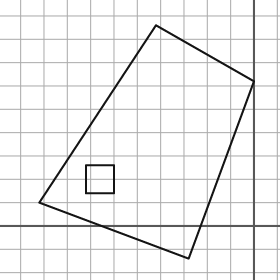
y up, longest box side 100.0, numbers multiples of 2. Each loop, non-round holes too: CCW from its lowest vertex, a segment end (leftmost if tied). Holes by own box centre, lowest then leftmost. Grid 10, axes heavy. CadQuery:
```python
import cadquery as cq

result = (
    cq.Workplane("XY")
    .moveTo(-28.0, -14.0)
    .lineTo(0.0, 62.0)
    .lineTo(-42.0, 86.0)
    .lineTo(-92.0, 10.0)
    .close()
    .moveTo(-72.0, 14.0)
    .lineTo(-60.0, 14.0)
    .lineTo(-60.0, 26.0)
    .lineTo(-72.0, 26.0)
    .close()
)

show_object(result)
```